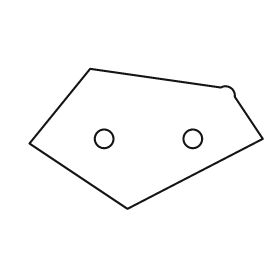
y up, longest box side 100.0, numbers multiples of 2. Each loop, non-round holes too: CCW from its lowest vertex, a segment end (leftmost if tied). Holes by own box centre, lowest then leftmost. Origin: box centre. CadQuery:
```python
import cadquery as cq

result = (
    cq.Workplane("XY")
    .moveTo(-8.0, -30.0)
    .lineTo(50.0, 0.0)
    .lineTo(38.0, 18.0)
    .threePointArc((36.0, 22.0), (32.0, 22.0))
    .lineTo(-24.0, 30.0)
    .lineTo(-50.0, -2.0)
    .close()
    .moveTo(-18.0, 0.0)
    .circle(4.0)
    .moveTo(20.0, 0.0)
    .circle(4.0)
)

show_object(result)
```